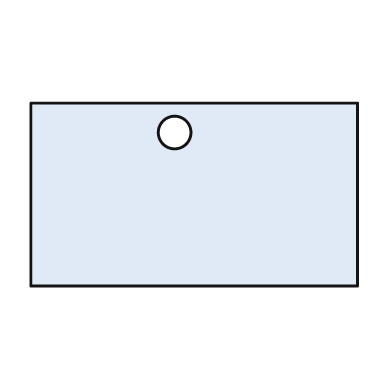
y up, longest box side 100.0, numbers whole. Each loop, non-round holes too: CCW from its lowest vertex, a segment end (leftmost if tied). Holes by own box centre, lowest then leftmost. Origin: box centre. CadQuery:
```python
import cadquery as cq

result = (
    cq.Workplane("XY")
    .moveTo(-50.0, -28.0)
    .lineTo(50.0, -28.0)
    .lineTo(50.0, 28.0)
    .lineTo(-50.0, 28.0)
    .close()
    .moveTo(-6.0, 19.0)
    .circle(5.0)
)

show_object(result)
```